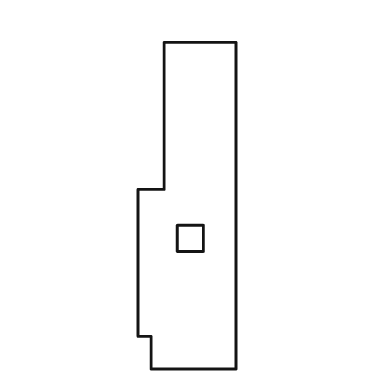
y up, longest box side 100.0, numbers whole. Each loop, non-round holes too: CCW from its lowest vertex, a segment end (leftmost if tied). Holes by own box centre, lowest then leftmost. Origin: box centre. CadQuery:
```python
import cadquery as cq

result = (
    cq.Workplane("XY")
    .moveTo(-11.0, -50.0)
    .lineTo(15.0, -50.0)
    .lineTo(15.0, 50.0)
    .lineTo(-7.0, 50.0)
    .lineTo(-7.0, 5.0)
    .lineTo(-15.0, 5.0)
    .lineTo(-15.0, -40.0)
    .lineTo(-11.0, -40.0)
    .close()
    .moveTo(-3.0, -14.0)
    .lineTo(5.0, -14.0)
    .lineTo(5.0, -6.0)
    .lineTo(-3.0, -6.0)
    .close()
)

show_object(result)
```